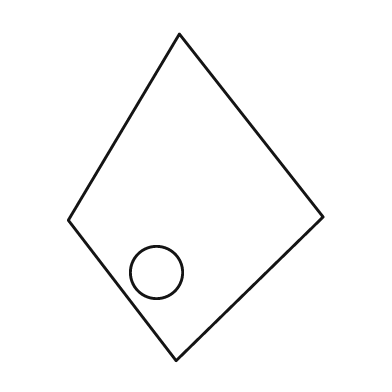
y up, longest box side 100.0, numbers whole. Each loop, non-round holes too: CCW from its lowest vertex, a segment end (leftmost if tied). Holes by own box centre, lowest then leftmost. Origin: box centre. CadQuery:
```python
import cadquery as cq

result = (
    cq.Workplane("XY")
    .moveTo(-6.0, -50.0)
    .lineTo(39.0, -6.0)
    .lineTo(-5.0, 50.0)
    .lineTo(-39.0, -7.0)
    .close()
    .moveTo(-12.0, -23.0)
    .circle(8.0)
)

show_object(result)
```